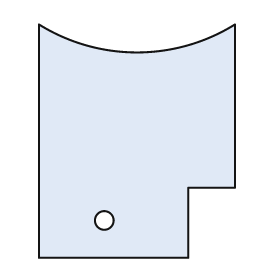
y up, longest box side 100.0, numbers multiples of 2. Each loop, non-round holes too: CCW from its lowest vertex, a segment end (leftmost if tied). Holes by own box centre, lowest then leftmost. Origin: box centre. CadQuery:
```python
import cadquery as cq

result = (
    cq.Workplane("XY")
    .moveTo(-42.0, -50.0)
    .lineTo(22.0, -50.0)
    .lineTo(22.0, -20.0)
    .lineTo(42.0, -20.0)
    .lineTo(42.0, 50.0)
    .threePointArc((0.0, 38.0), (-42.0, 50.0))
    .close()
    .moveTo(-14.0, -34.0)
    .circle(4.0)
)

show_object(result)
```